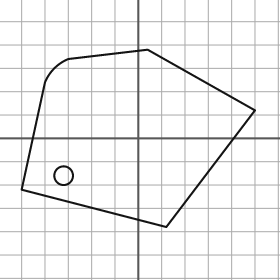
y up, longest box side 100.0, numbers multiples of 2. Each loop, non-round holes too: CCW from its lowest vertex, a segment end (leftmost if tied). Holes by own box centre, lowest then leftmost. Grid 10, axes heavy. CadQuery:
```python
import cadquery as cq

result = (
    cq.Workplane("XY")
    .moveTo(12.0, -38.0)
    .lineTo(50.0, 12.0)
    .lineTo(4.0, 38.0)
    .lineTo(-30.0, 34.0)
    .threePointArc((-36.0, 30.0), (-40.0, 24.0))
    .lineTo(-50.0, -22.0)
    .close()
    .moveTo(-32.0, -16.0)
    .circle(4.0)
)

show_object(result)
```